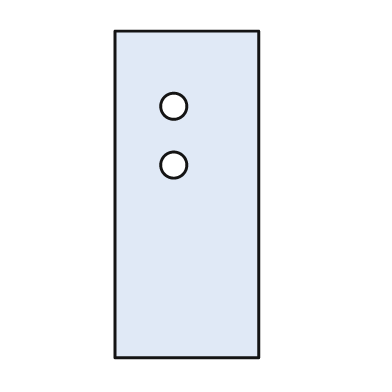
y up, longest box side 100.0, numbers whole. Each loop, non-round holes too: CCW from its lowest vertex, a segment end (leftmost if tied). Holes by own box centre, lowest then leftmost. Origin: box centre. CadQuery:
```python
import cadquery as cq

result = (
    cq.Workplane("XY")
    .moveTo(-22.0, -50.0)
    .lineTo(22.0, -50.0)
    .lineTo(22.0, 50.0)
    .lineTo(-22.0, 50.0)
    .close()
    .moveTo(-4.0, 9.0)
    .circle(4.0)
    .moveTo(-4.0, 27.0)
    .circle(4.0)
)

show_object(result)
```